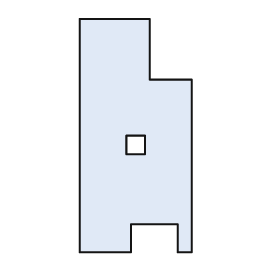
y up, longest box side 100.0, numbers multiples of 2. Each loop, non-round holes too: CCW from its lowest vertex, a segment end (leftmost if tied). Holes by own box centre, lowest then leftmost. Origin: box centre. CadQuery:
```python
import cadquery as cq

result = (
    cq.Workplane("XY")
    .moveTo(-24.0, -50.0)
    .lineTo(-2.0, -50.0)
    .lineTo(-2.0, -38.0)
    .lineTo(18.0, -38.0)
    .lineTo(18.0, -50.0)
    .lineTo(24.0, -50.0)
    .lineTo(24.0, 24.0)
    .lineTo(6.0, 24.0)
    .lineTo(6.0, 50.0)
    .lineTo(-24.0, 50.0)
    .close()
    .moveTo(-4.0, -8.0)
    .lineTo(4.0, -8.0)
    .lineTo(4.0, 0.0)
    .lineTo(-4.0, 0.0)
    .close()
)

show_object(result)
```